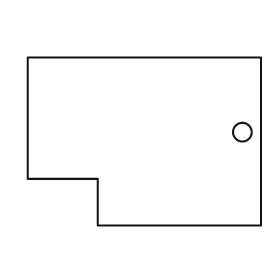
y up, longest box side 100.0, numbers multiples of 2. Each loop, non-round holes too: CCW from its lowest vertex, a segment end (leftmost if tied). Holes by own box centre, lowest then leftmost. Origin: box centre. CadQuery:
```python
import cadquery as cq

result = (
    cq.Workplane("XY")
    .moveTo(-20.0, -36.0)
    .lineTo(50.0, -36.0)
    .lineTo(50.0, 36.0)
    .lineTo(-50.0, 36.0)
    .lineTo(-50.0, -16.0)
    .lineTo(-20.0, -16.0)
    .close()
    .moveTo(42.0, 4.0)
    .circle(4.0)
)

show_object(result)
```